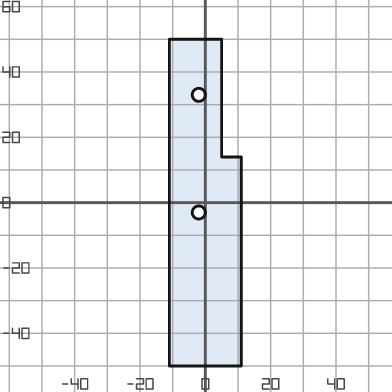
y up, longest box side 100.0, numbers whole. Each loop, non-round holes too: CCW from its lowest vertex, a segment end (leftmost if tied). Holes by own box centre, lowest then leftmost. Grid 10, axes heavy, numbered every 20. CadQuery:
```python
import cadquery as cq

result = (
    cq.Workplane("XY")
    .moveTo(-11.0, -50.0)
    .lineTo(11.0, -50.0)
    .lineTo(11.0, 14.0)
    .lineTo(5.0, 14.0)
    .lineTo(5.0, 50.0)
    .lineTo(-11.0, 50.0)
    .close()
    .moveTo(-2.0, -3.0)
    .circle(2.0)
    .moveTo(-2.0, 33.0)
    .circle(2.0)
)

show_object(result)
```